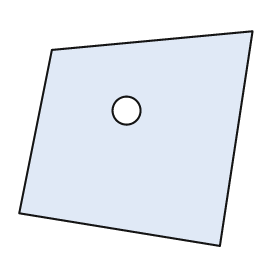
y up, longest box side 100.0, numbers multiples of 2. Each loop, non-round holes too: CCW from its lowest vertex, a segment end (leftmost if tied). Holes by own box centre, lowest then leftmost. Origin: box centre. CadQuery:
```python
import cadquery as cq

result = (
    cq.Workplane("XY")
    .moveTo(36.0, -46.0)
    .lineTo(50.0, 46.0)
    .lineTo(-36.0, 38.0)
    .lineTo(-50.0, -32.0)
    .close()
    .moveTo(-4.0, 12.0)
    .circle(6.0)
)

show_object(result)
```